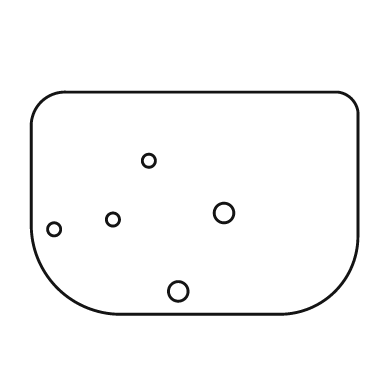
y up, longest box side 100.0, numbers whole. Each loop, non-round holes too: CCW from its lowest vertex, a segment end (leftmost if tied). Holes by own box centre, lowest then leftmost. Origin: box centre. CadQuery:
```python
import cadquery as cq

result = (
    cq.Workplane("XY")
    .moveTo(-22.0, -34.0)
    .lineTo(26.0, -34.0)
    .threePointArc((43.0, -27.0), (50.0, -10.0))
    .lineTo(50.0, 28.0)
    .threePointArc((48.0, 32.0), (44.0, 34.0))
    .lineTo(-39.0, 34.0)
    .threePointArc((-47.0, 31.0), (-50.0, 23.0))
    .lineTo(-50.0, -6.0)
    .threePointArc((-42.0, -26.0), (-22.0, -34.0))
    .close()
    .moveTo(-5.0, -27.0)
    .circle(3.0)
    .moveTo(-43.0, -8.0)
    .circle(2.0)
    .moveTo(-25.0, -5.0)
    .circle(2.0)
    .moveTo(9.0, -3.0)
    .circle(3.0)
    .moveTo(-14.0, 13.0)
    .circle(2.0)
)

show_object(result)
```